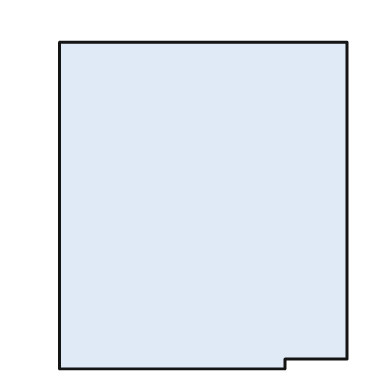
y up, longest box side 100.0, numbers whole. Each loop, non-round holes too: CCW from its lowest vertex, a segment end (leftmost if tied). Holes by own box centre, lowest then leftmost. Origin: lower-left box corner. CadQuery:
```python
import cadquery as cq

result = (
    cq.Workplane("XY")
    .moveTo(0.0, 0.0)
    .lineTo(69.0, 0.0)
    .lineTo(69.0, 3.0)
    .lineTo(88.0, 3.0)
    .lineTo(88.0, 100.0)
    .lineTo(0.0, 100.0)
    .close()
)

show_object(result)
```